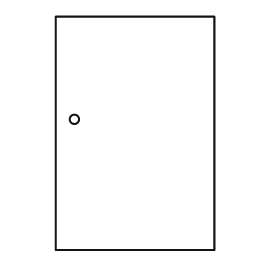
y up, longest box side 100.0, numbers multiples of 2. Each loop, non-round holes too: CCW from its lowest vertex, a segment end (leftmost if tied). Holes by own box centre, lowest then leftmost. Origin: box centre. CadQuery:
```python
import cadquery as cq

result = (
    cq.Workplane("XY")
    .moveTo(-34.0, -50.0)
    .lineTo(34.0, -50.0)
    .lineTo(34.0, 50.0)
    .lineTo(-34.0, 50.0)
    .close()
    .moveTo(-26.0, 6.0)
    .circle(2.0)
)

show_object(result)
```